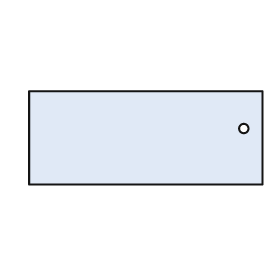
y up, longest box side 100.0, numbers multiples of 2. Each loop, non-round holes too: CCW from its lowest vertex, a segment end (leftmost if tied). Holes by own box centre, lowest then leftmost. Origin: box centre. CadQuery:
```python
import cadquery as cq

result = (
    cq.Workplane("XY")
    .moveTo(-50.0, -20.0)
    .lineTo(50.0, -20.0)
    .lineTo(50.0, 20.0)
    .lineTo(-50.0, 20.0)
    .close()
    .moveTo(42.0, 4.0)
    .circle(2.0)
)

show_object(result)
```